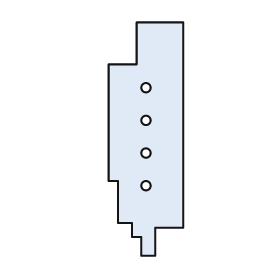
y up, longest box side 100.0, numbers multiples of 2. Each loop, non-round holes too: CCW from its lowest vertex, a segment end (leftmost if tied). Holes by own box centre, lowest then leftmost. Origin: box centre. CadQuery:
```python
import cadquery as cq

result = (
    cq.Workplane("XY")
    .moveTo(-2.0, -50.0)
    .lineTo(4.0, -50.0)
    .lineTo(4.0, -38.0)
    .lineTo(16.0, -38.0)
    .lineTo(16.0, 50.0)
    .lineTo(-4.0, 50.0)
    .lineTo(-4.0, 32.0)
    .lineTo(-16.0, 32.0)
    .lineTo(-16.0, -18.0)
    .lineTo(-12.0, -18.0)
    .lineTo(-12.0, -36.0)
    .lineTo(-6.0, -36.0)
    .lineTo(-6.0, -42.0)
    .lineTo(-2.0, -42.0)
    .close()
    .moveTo(0.0, -20.0)
    .circle(2.0)
    .moveTo(0.0, -6.0)
    .circle(2.0)
    .moveTo(0.0, 8.0)
    .circle(2.0)
    .moveTo(0.0, 22.0)
    .circle(2.0)
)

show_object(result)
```